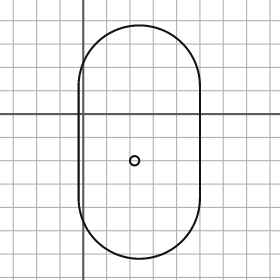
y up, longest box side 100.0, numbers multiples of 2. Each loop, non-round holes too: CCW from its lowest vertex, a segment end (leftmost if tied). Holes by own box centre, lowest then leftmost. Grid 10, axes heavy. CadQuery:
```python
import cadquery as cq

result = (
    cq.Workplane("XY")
    .moveTo(-2.0, -36.0)
    .threePointArc((24.0, -62.0), (50.0, -36.0))
    .lineTo(50.0, 12.0)
    .threePointArc((24.0, 38.0), (-2.0, 12.0))
    .close()
    .moveTo(22.0, -20.0)
    .circle(2.0)
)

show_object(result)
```